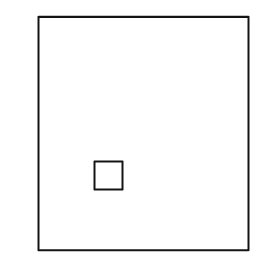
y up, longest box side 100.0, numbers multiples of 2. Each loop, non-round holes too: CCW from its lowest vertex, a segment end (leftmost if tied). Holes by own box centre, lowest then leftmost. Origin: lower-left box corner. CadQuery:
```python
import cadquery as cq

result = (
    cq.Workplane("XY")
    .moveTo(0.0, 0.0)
    .lineTo(90.0, 0.0)
    .lineTo(90.0, 100.0)
    .lineTo(0.0, 100.0)
    .close()
    .moveTo(24.0, 26.0)
    .lineTo(36.0, 26.0)
    .lineTo(36.0, 38.0)
    .lineTo(24.0, 38.0)
    .close()
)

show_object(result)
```